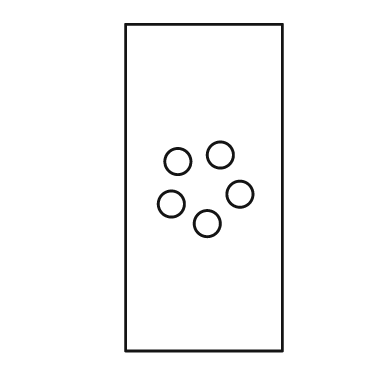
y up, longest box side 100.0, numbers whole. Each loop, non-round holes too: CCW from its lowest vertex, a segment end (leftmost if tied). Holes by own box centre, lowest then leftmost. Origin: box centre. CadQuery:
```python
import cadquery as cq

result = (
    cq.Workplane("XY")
    .moveTo(-24.0, -50.0)
    .lineTo(24.0, -50.0)
    .lineTo(24.0, 50.0)
    .lineTo(-24.0, 50.0)
    .close()
    .moveTo(1.0, -11.0)
    .circle(4.0)
    .moveTo(-10.0, -5.0)
    .circle(4.0)
    .moveTo(11.0, -2.0)
    .circle(4.0)
    .moveTo(-8.0, 8.0)
    .circle(4.0)
    .moveTo(5.0, 10.0)
    .circle(4.0)
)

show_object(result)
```